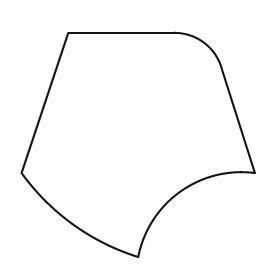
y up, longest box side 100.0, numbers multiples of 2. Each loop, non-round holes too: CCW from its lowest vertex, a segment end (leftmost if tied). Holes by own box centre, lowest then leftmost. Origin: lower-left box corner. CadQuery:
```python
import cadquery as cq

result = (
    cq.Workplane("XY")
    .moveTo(50.0, 0.0)
    .threePointArc((68.0, 28.0), (100.0, 36.0))
    .lineTo(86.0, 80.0)
    .threePointArc((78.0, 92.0), (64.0, 96.0))
    .lineTo(20.0, 96.0)
    .lineTo(0.0, 36.0)
    .threePointArc((22.0, 14.0), (50.0, 0.0))
    .close()
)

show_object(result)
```